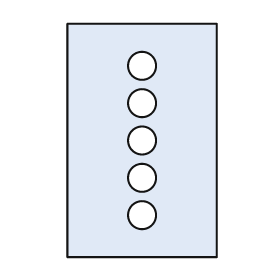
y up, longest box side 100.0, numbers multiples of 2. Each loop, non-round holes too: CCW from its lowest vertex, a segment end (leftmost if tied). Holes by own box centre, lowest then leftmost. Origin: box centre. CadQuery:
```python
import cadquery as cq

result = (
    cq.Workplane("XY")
    .moveTo(-32.0, -50.0)
    .lineTo(32.0, -50.0)
    .lineTo(32.0, 50.0)
    .lineTo(-32.0, 50.0)
    .close()
    .moveTo(0.0, -32.0)
    .circle(6.0)
    .moveTo(0.0, -16.0)
    .circle(6.0)
    .moveTo(0.0, 0.0)
    .circle(6.0)
    .moveTo(0.0, 16.0)
    .circle(6.0)
    .moveTo(0.0, 32.0)
    .circle(6.0)
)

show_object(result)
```